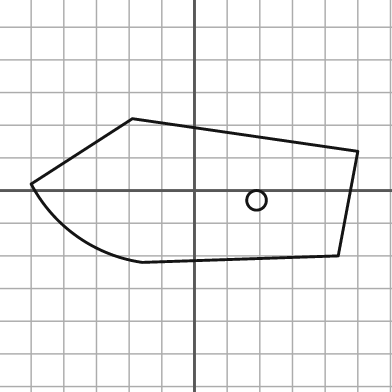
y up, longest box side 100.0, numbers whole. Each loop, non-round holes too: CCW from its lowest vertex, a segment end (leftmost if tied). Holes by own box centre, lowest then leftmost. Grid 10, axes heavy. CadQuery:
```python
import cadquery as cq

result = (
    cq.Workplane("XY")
    .moveTo(-16.0, -22.0)
    .lineTo(44.0, -20.0)
    .lineTo(50.0, 12.0)
    .lineTo(-19.0, 22.0)
    .lineTo(-50.0, 2.0)
    .threePointArc((-36.0, -14.0), (-16.0, -22.0))
    .close()
    .moveTo(19.0, -3.0)
    .circle(3.0)
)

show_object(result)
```